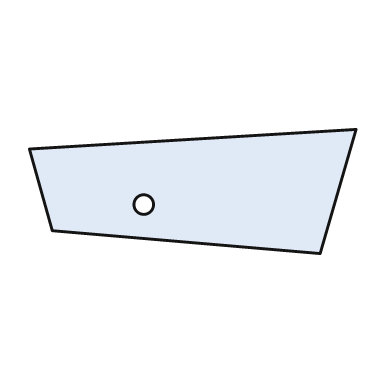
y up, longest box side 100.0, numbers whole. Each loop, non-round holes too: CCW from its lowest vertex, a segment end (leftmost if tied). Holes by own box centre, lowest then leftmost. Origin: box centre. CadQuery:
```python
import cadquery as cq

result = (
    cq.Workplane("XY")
    .moveTo(39.0, -19.0)
    .lineTo(50.0, 19.0)
    .lineTo(-50.0, 13.0)
    .lineTo(-43.0, -12.0)
    .close()
    .moveTo(-15.0, -4.0)
    .circle(3.0)
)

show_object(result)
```